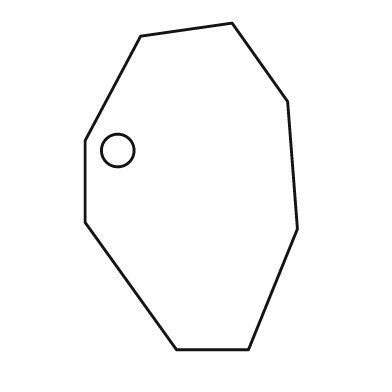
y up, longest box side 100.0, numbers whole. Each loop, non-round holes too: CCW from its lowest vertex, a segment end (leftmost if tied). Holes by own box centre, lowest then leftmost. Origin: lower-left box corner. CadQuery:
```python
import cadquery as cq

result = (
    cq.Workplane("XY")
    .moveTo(28.0, 0.0)
    .lineTo(50.0, 0.0)
    .lineTo(65.0, 37.0)
    .lineTo(62.0, 76.0)
    .lineTo(45.0, 100.0)
    .lineTo(17.0, 96.0)
    .lineTo(0.0, 64.0)
    .lineTo(0.0, 39.0)
    .close()
    .moveTo(10.0, 61.0)
    .circle(5.0)
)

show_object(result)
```